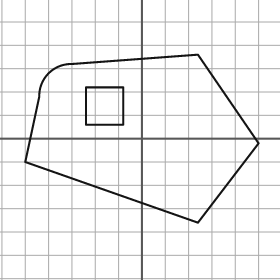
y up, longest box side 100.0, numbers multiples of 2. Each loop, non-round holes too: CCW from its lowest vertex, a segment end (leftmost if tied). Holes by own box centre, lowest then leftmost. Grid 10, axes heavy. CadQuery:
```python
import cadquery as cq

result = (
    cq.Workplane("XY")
    .moveTo(24.0, -36.0)
    .lineTo(50.0, -2.0)
    .lineTo(24.0, 36.0)
    .lineTo(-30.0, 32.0)
    .threePointArc((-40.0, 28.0), (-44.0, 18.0))
    .lineTo(-50.0, -10.0)
    .close()
    .moveTo(-24.0, 6.0)
    .lineTo(-8.0, 6.0)
    .lineTo(-8.0, 22.0)
    .lineTo(-24.0, 22.0)
    .close()
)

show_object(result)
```